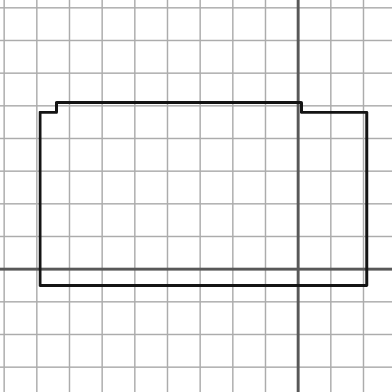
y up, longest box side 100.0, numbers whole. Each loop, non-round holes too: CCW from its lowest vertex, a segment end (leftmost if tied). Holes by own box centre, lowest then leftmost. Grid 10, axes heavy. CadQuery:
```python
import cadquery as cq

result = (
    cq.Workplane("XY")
    .moveTo(-79.0, -5.0)
    .lineTo(21.0, -5.0)
    .lineTo(21.0, 48.0)
    .lineTo(1.0, 48.0)
    .lineTo(1.0, 51.0)
    .lineTo(-74.0, 51.0)
    .lineTo(-74.0, 48.0)
    .lineTo(-79.0, 48.0)
    .close()
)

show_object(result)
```